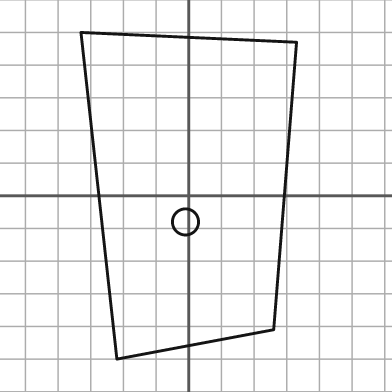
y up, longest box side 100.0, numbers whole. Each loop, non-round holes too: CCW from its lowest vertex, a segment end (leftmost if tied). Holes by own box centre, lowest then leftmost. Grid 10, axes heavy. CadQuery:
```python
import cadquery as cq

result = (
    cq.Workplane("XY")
    .moveTo(-22.0, -50.0)
    .lineTo(26.0, -41.0)
    .lineTo(33.0, 47.0)
    .lineTo(-33.0, 50.0)
    .close()
    .moveTo(-1.0, -8.0)
    .circle(4.0)
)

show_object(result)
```